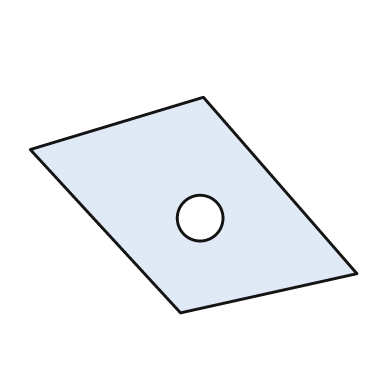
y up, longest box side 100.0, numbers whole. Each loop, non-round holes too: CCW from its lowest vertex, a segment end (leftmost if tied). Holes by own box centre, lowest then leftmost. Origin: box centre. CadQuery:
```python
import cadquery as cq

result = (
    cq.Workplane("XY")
    .moveTo(-4.0, -33.0)
    .lineTo(50.0, -21.0)
    .lineTo(3.0, 33.0)
    .lineTo(-50.0, 17.0)
    .close()
    .moveTo(2.0, -4.0)
    .circle(7.0)
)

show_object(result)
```